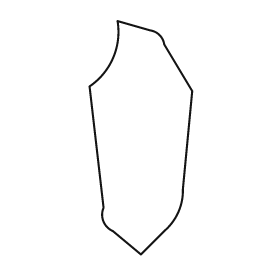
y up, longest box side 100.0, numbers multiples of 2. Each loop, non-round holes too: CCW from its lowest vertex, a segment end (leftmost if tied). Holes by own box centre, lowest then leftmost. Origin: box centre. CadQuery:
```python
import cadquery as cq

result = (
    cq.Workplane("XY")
    .moveTo(0.0, -50.0)
    .lineTo(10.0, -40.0)
    .threePointArc((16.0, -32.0), (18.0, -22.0))
    .lineTo(22.0, 20.0)
    .lineTo(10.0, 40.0)
    .threePointArc((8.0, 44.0), (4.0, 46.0))
    .lineTo(-10.0, 50.0)
    .threePointArc((-12.0, 34.0), (-22.0, 22.0))
    .lineTo(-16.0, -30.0)
    .threePointArc((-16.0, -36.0), (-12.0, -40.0))
    .close()
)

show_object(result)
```